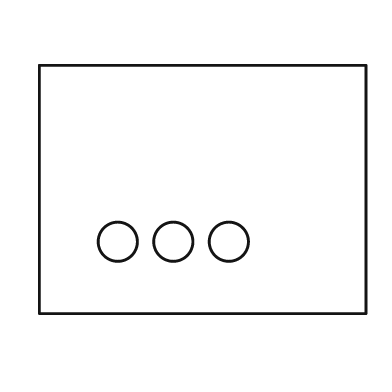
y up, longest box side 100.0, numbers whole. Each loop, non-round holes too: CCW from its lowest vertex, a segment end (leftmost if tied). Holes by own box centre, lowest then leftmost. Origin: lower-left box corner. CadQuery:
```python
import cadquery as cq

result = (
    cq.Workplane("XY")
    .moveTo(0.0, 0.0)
    .lineTo(100.0, 0.0)
    .lineTo(100.0, 76.0)
    .lineTo(0.0, 76.0)
    .close()
    .moveTo(24.0, 22.0)
    .circle(6.0)
    .moveTo(41.0, 22.0)
    .circle(6.0)
    .moveTo(58.0, 22.0)
    .circle(6.0)
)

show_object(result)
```